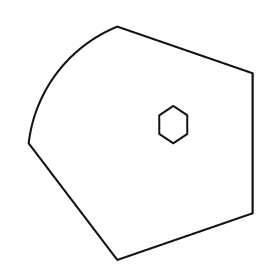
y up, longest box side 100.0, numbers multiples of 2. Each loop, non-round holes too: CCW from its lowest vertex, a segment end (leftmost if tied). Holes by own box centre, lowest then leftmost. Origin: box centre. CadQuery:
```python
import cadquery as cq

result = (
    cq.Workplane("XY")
    .moveTo(-10.0, -50.0)
    .lineTo(48.0, -30.0)
    .lineTo(48.0, 30.0)
    .lineTo(-10.0, 50.0)
    .threePointArc((-36.0, 30.0), (-48.0, 0.0))
    .close()
    .moveTo(14.0, 0.0)
    .lineTo(20.0, 4.0)
    .lineTo(20.0, 12.0)
    .lineTo(14.0, 16.0)
    .lineTo(8.0, 12.0)
    .lineTo(8.0, 4.0)
    .close()
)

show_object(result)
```